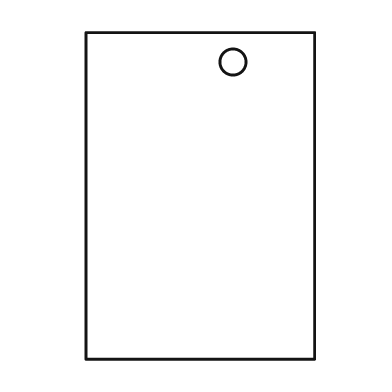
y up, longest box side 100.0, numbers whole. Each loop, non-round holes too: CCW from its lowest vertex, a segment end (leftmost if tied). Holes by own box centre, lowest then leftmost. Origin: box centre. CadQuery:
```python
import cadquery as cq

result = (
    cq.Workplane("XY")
    .moveTo(-35.0, -50.0)
    .lineTo(35.0, -50.0)
    .lineTo(35.0, 50.0)
    .lineTo(-35.0, 50.0)
    .close()
    .moveTo(10.0, 41.0)
    .circle(4.0)
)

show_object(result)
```